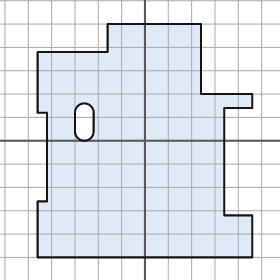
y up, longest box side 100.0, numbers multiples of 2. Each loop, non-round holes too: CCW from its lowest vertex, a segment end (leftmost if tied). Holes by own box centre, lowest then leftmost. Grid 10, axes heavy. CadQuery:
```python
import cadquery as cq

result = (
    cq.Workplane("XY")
    .moveTo(-46.0, -50.0)
    .lineTo(46.0, -50.0)
    .lineTo(46.0, -32.0)
    .lineTo(34.0, -32.0)
    .lineTo(34.0, 14.0)
    .lineTo(46.0, 14.0)
    .lineTo(46.0, 20.0)
    .lineTo(24.0, 20.0)
    .lineTo(24.0, 50.0)
    .lineTo(-16.0, 50.0)
    .lineTo(-16.0, 38.0)
    .lineTo(-46.0, 38.0)
    .lineTo(-46.0, 12.0)
    .lineTo(-42.0, 12.0)
    .lineTo(-42.0, -26.0)
    .lineTo(-46.0, -26.0)
    .close()
    .moveTo(-30.0, 4.0)
    .threePointArc((-26.0, 0.0), (-22.0, 4.0))
    .lineTo(-22.0, 12.0)
    .threePointArc((-26.0, 16.0), (-30.0, 12.0))
    .close()
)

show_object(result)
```